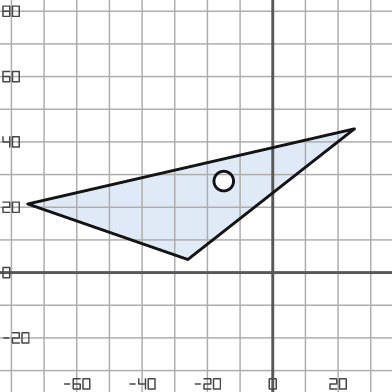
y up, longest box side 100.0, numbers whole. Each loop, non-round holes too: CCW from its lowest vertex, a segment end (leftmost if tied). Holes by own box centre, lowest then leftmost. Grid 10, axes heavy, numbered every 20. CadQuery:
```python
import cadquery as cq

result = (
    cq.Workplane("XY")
    .moveTo(-26.0, 4.0)
    .lineTo(25.0, 44.0)
    .lineTo(-75.0, 21.0)
    .close()
    .moveTo(-15.0, 28.0)
    .circle(3.0)
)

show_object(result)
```